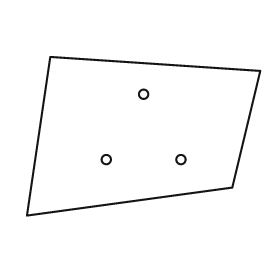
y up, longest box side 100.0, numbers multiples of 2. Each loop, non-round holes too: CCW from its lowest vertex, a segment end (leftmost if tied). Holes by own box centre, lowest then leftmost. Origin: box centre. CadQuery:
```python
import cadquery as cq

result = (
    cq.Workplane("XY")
    .moveTo(-50.0, -34.0)
    .lineTo(38.0, -22.0)
    .lineTo(50.0, 28.0)
    .lineTo(-40.0, 34.0)
    .close()
    .moveTo(-16.0, -10.0)
    .circle(2.0)
    .moveTo(16.0, -10.0)
    .circle(2.0)
    .moveTo(0.0, 18.0)
    .circle(2.0)
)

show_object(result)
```